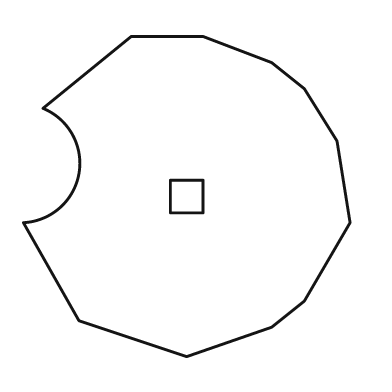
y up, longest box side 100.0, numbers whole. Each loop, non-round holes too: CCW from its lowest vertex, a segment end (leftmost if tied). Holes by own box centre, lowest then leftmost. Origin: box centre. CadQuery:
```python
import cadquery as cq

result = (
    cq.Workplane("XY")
    .moveTo(0.0, -49.0)
    .lineTo(26.0, -40.0)
    .lineTo(36.0, -32.0)
    .lineTo(50.0, -8.0)
    .lineTo(46.0, 17.0)
    .lineTo(36.0, 33.0)
    .lineTo(26.0, 41.0)
    .lineTo(5.0, 49.0)
    .lineTo(-17.0, 49.0)
    .lineTo(-44.0, 27.0)
    .threePointArc((-33.0, 7.0), (-50.0, -8.0))
    .lineTo(-33.0, -38.0)
    .close()
    .moveTo(-5.0, -5.0)
    .lineTo(5.0, -5.0)
    .lineTo(5.0, 5.0)
    .lineTo(-5.0, 5.0)
    .close()
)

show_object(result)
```